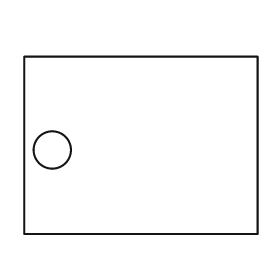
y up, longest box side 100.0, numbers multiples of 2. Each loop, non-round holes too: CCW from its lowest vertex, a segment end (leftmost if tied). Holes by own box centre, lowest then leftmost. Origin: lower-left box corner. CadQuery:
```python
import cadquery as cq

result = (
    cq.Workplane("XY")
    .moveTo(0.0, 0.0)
    .lineTo(100.0, 0.0)
    .lineTo(100.0, 76.0)
    .lineTo(0.0, 76.0)
    .close()
    .moveTo(12.0, 36.0)
    .circle(8.0)
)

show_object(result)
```